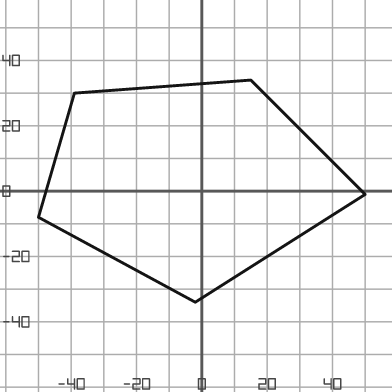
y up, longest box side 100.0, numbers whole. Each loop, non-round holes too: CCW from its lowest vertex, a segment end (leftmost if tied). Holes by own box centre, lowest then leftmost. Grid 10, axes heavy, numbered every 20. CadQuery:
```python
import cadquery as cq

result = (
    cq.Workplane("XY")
    .moveTo(-2.0, -34.0)
    .lineTo(50.0, -1.0)
    .lineTo(15.0, 34.0)
    .lineTo(-39.0, 30.0)
    .lineTo(-50.0, -8.0)
    .close()
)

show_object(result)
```